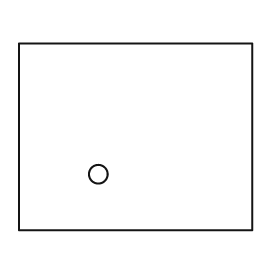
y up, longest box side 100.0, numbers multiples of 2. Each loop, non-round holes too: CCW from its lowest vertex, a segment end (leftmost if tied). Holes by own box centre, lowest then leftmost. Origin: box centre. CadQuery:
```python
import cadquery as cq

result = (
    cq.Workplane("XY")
    .moveTo(-50.0, -40.0)
    .lineTo(50.0, -40.0)
    .lineTo(50.0, 40.0)
    .lineTo(-50.0, 40.0)
    .close()
    .moveTo(-16.0, -16.0)
    .circle(4.0)
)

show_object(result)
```